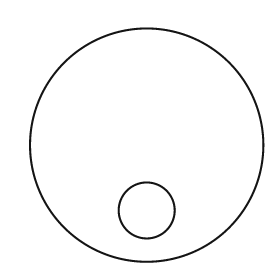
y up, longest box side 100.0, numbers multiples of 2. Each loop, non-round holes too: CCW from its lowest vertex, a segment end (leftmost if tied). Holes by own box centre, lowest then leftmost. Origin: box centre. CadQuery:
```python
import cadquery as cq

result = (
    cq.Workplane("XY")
    .moveTo(0.0, 0.0)
    .circle(50.0)
    .moveTo(0.0, -28.0)
    .circle(12.0)
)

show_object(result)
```